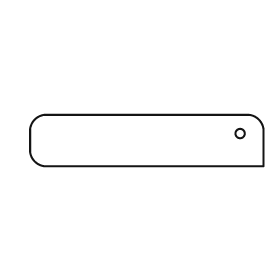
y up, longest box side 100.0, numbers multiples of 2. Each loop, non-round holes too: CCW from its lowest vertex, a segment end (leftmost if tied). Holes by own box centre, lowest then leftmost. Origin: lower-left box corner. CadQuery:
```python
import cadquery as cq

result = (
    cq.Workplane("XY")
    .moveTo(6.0, 0.0)
    .lineTo(100.0, 0.0)
    .lineTo(100.0, 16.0)
    .threePointArc((98.0, 20.0), (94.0, 22.0))
    .lineTo(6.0, 22.0)
    .threePointArc((2.0, 20.0), (0.0, 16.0))
    .lineTo(0.0, 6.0)
    .threePointArc((2.0, 2.0), (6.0, 0.0))
    .close()
    .moveTo(90.0, 14.0)
    .circle(2.0)
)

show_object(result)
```